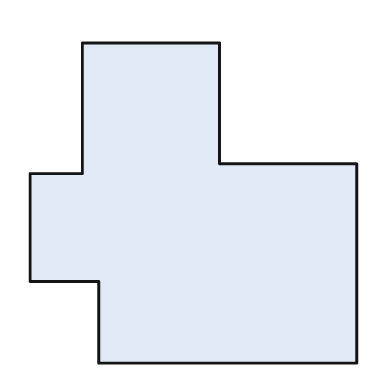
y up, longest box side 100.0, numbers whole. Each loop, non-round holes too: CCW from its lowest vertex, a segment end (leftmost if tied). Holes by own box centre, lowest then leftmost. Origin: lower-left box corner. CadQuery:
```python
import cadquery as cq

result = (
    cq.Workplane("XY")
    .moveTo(21.0, 0.0)
    .lineTo(100.0, 0.0)
    .lineTo(100.0, 61.0)
    .lineTo(58.0, 61.0)
    .lineTo(58.0, 98.0)
    .lineTo(16.0, 98.0)
    .lineTo(16.0, 58.0)
    .lineTo(0.0, 58.0)
    .lineTo(0.0, 25.0)
    .lineTo(21.0, 25.0)
    .close()
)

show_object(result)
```